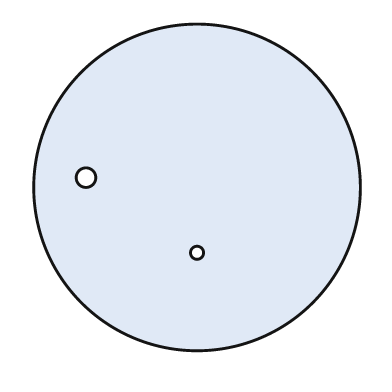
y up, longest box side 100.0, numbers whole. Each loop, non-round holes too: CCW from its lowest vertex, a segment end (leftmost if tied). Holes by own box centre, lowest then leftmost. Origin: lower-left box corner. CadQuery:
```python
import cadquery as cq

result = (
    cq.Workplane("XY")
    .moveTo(50.0, 50.0)
    .circle(50.0)
    .moveTo(50.0, 30.0)
    .circle(2.0)
    .moveTo(16.0, 53.0)
    .circle(3.0)
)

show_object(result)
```